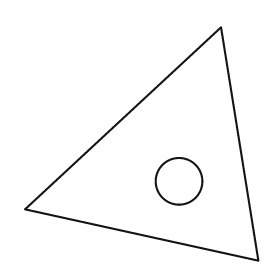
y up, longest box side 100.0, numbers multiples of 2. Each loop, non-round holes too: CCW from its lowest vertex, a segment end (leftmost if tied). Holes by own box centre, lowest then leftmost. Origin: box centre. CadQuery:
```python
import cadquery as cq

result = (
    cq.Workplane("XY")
    .moveTo(50.0, -50.0)
    .lineTo(34.0, 50.0)
    .lineTo(-50.0, -28.0)
    .close()
    .moveTo(16.0, -16.0)
    .circle(10.0)
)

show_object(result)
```